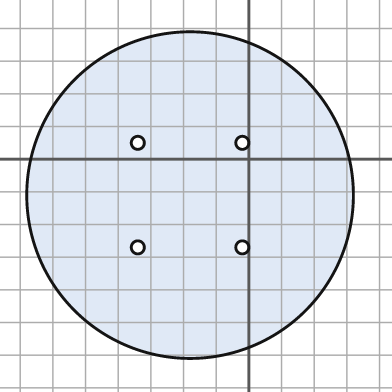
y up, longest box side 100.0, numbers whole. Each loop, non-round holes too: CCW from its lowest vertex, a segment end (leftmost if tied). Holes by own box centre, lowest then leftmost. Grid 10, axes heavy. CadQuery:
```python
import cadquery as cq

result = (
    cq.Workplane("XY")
    .moveTo(-18.0, -11.0)
    .circle(50.0)
    .moveTo(-34.0, -27.0)
    .circle(2.0)
    .moveTo(-2.0, -27.0)
    .circle(2.0)
    .moveTo(-34.0, 5.0)
    .circle(2.0)
    .moveTo(-2.0, 5.0)
    .circle(2.0)
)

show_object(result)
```